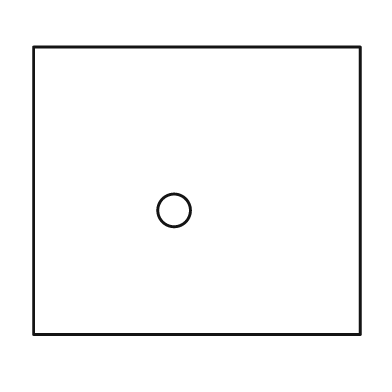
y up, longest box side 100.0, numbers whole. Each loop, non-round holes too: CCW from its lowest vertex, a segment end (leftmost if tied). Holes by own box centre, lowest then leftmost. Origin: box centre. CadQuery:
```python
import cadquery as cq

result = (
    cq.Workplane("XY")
    .moveTo(-50.0, -44.0)
    .lineTo(50.0, -44.0)
    .lineTo(50.0, 44.0)
    .lineTo(-50.0, 44.0)
    .close()
    .moveTo(-7.0, -6.0)
    .circle(5.0)
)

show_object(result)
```